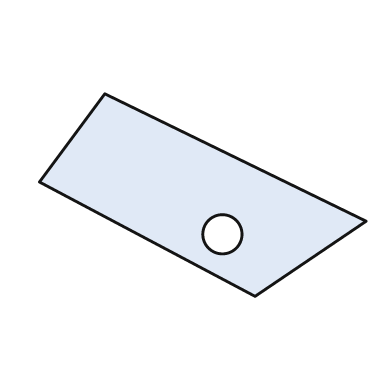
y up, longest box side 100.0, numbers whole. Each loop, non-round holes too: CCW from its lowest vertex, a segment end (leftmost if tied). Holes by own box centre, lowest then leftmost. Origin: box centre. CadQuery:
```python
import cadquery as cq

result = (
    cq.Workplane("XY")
    .moveTo(16.0, -31.0)
    .lineTo(50.0, -8.0)
    .lineTo(-30.0, 31.0)
    .lineTo(-50.0, 4.0)
    .close()
    .moveTo(6.0, -12.0)
    .circle(6.0)
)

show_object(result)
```